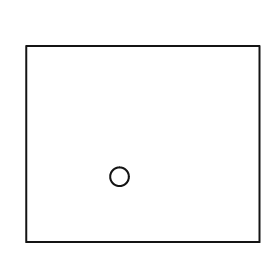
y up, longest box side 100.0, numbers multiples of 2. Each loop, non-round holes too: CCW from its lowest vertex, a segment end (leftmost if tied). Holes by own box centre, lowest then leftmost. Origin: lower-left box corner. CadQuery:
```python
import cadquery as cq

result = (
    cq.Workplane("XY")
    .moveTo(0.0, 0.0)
    .lineTo(100.0, 0.0)
    .lineTo(100.0, 84.0)
    .lineTo(0.0, 84.0)
    .close()
    .moveTo(40.0, 28.0)
    .circle(4.0)
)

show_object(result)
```